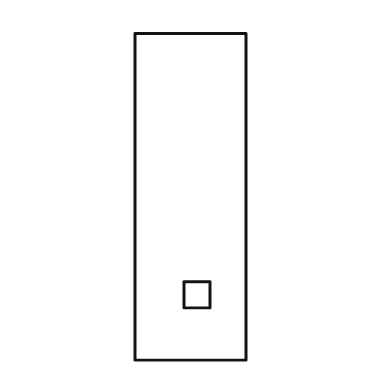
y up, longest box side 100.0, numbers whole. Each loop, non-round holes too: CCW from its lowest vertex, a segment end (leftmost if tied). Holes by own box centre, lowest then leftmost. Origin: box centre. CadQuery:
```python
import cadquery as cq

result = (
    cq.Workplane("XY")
    .moveTo(-17.0, -50.0)
    .lineTo(17.0, -50.0)
    .lineTo(17.0, 50.0)
    .lineTo(-17.0, 50.0)
    .close()
    .moveTo(-2.0, -34.0)
    .lineTo(6.0, -34.0)
    .lineTo(6.0, -26.0)
    .lineTo(-2.0, -26.0)
    .close()
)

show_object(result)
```